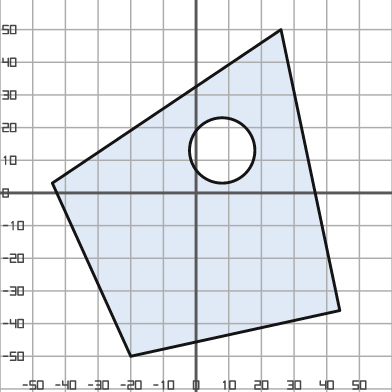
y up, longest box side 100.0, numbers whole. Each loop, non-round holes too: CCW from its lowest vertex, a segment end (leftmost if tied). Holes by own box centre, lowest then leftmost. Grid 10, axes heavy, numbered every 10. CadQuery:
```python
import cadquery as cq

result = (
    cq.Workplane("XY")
    .moveTo(-20.0, -50.0)
    .lineTo(44.0, -36.0)
    .lineTo(26.0, 50.0)
    .lineTo(-44.0, 3.0)
    .close()
    .moveTo(8.0, 13.0)
    .circle(10.0)
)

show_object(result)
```